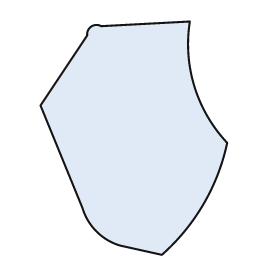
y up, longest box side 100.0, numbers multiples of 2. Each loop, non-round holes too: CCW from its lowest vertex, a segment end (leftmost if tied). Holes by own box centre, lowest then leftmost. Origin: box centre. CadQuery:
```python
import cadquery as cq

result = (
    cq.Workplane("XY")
    .moveTo(12.0, -50.0)
    .threePointArc((30.0, -28.0), (40.0, -2.0))
    .threePointArc((26.0, 22.0), (24.0, 50.0))
    .lineTo(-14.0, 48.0)
    .threePointArc((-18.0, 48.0), (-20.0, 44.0))
    .lineTo(-40.0, 14.0)
    .lineTo(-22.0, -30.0)
    .threePointArc((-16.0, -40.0), (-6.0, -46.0))
    .close()
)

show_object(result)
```